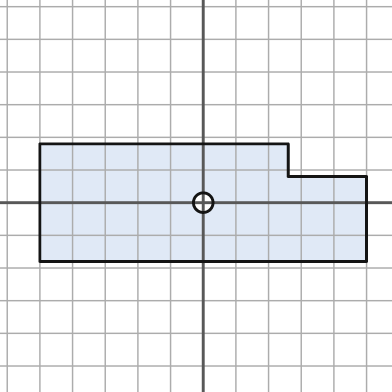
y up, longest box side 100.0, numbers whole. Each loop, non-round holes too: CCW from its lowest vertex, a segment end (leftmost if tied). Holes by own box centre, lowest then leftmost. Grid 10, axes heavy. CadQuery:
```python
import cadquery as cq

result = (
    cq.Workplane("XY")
    .moveTo(-50.0, -18.0)
    .lineTo(50.0, -18.0)
    .lineTo(50.0, 8.0)
    .lineTo(26.0, 8.0)
    .lineTo(26.0, 18.0)
    .lineTo(-50.0, 18.0)
    .close()
    .moveTo(0.0, 0.0)
    .circle(3.0)
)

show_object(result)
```